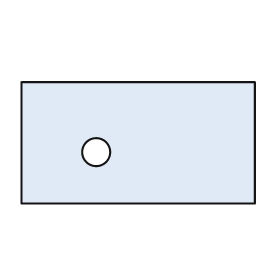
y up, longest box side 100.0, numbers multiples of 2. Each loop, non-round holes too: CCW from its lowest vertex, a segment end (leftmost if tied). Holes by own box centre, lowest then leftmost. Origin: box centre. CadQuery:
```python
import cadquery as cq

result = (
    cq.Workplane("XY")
    .moveTo(-50.0, -26.0)
    .lineTo(50.0, -26.0)
    .lineTo(50.0, 26.0)
    .lineTo(-50.0, 26.0)
    .close()
    .moveTo(-18.0, -4.0)
    .circle(6.0)
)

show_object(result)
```